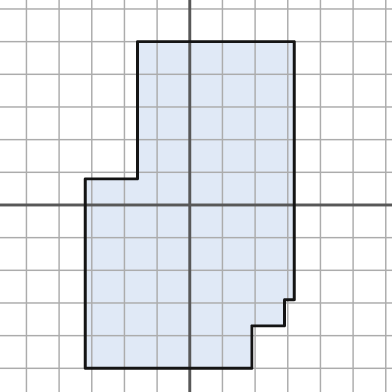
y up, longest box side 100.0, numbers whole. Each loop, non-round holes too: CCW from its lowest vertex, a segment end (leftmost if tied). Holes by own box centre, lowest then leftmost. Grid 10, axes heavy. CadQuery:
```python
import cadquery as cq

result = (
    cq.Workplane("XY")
    .moveTo(-32.0, -50.0)
    .lineTo(19.0, -50.0)
    .lineTo(19.0, -37.0)
    .lineTo(29.0, -37.0)
    .lineTo(29.0, -29.0)
    .lineTo(32.0, -29.0)
    .lineTo(32.0, 50.0)
    .lineTo(-16.0, 50.0)
    .lineTo(-16.0, 8.0)
    .lineTo(-32.0, 8.0)
    .close()
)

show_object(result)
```